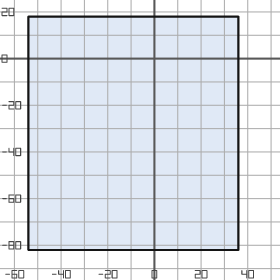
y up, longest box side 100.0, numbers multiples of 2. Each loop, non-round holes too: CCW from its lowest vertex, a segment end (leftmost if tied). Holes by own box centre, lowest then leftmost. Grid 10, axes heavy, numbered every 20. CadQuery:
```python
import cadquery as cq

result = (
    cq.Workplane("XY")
    .moveTo(-54.0, -82.0)
    .lineTo(36.0, -82.0)
    .lineTo(36.0, 18.0)
    .lineTo(-54.0, 18.0)
    .close()
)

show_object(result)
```